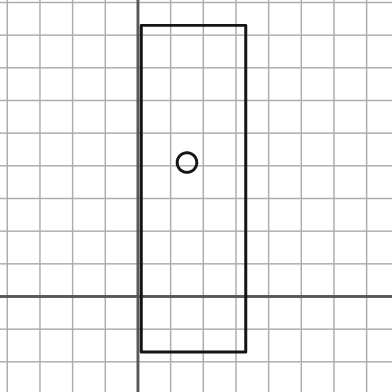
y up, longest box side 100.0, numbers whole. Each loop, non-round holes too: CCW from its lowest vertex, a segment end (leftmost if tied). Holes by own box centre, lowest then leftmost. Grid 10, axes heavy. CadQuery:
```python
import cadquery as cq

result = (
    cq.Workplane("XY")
    .moveTo(1.0, -17.0)
    .lineTo(33.0, -17.0)
    .lineTo(33.0, 83.0)
    .lineTo(1.0, 83.0)
    .close()
    .moveTo(15.0, 41.0)
    .circle(3.0)
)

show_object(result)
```